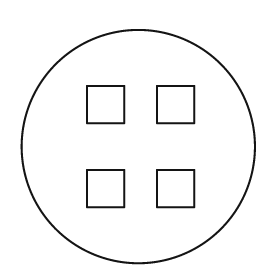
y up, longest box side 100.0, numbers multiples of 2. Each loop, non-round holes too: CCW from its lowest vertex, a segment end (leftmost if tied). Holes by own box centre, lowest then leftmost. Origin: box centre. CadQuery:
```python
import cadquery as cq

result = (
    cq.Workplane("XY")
    .moveTo(0.0, 0.0)
    .circle(50.0)
    .moveTo(-22.0, -26.0)
    .lineTo(-6.0, -26.0)
    .lineTo(-6.0, -10.0)
    .lineTo(-22.0, -10.0)
    .close()
    .moveTo(8.0, -26.0)
    .lineTo(24.0, -26.0)
    .lineTo(24.0, -10.0)
    .lineTo(8.0, -10.0)
    .close()
    .moveTo(-22.0, 10.0)
    .lineTo(-6.0, 10.0)
    .lineTo(-6.0, 26.0)
    .lineTo(-22.0, 26.0)
    .close()
    .moveTo(8.0, 10.0)
    .lineTo(24.0, 10.0)
    .lineTo(24.0, 26.0)
    .lineTo(8.0, 26.0)
    .close()
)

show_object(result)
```